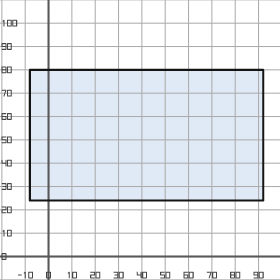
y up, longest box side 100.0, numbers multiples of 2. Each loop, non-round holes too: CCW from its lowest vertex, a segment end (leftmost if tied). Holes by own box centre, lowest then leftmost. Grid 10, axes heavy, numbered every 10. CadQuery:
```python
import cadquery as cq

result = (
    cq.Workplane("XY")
    .moveTo(-8.0, 24.0)
    .lineTo(92.0, 24.0)
    .lineTo(92.0, 80.0)
    .lineTo(-8.0, 80.0)
    .close()
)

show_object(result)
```